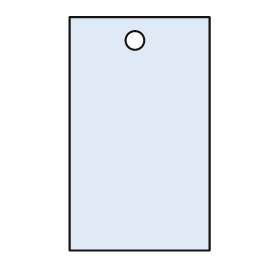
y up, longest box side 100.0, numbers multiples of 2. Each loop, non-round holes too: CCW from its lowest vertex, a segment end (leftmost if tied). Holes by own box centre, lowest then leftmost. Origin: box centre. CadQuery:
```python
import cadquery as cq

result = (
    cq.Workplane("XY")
    .moveTo(-30.0, -50.0)
    .lineTo(30.0, -50.0)
    .lineTo(30.0, 50.0)
    .lineTo(-30.0, 50.0)
    .close()
    .moveTo(-2.0, 40.0)
    .circle(4.0)
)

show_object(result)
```